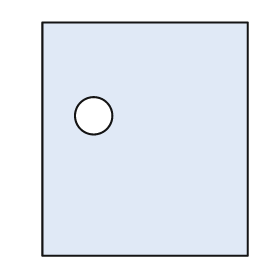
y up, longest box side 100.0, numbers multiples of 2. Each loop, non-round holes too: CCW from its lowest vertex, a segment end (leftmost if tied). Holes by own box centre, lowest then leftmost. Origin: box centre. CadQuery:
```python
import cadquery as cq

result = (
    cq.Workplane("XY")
    .moveTo(-44.0, -50.0)
    .lineTo(44.0, -50.0)
    .lineTo(44.0, 50.0)
    .lineTo(-44.0, 50.0)
    .close()
    .moveTo(-22.0, 10.0)
    .circle(8.0)
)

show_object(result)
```